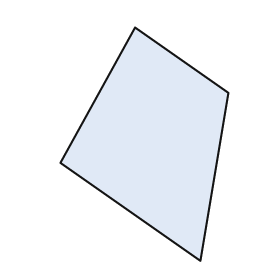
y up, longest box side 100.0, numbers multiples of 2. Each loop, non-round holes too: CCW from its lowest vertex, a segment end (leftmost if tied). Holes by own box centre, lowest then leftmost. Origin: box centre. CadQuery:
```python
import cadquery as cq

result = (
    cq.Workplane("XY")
    .moveTo(24.0, -50.0)
    .lineTo(36.0, 22.0)
    .lineTo(-4.0, 50.0)
    .lineTo(-36.0, -8.0)
    .close()
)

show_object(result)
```